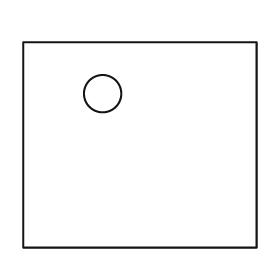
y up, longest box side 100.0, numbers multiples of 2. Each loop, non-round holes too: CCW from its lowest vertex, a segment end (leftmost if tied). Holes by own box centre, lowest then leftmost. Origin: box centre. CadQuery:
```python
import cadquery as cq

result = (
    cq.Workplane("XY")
    .moveTo(-50.0, -44.0)
    .lineTo(50.0, -44.0)
    .lineTo(50.0, 44.0)
    .lineTo(-50.0, 44.0)
    .close()
    .moveTo(-16.0, 22.0)
    .circle(8.0)
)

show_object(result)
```